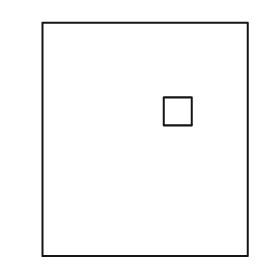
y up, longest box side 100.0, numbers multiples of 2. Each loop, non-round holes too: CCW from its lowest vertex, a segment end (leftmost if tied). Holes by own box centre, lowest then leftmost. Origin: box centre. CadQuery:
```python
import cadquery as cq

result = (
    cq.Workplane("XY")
    .moveTo(-44.0, -50.0)
    .lineTo(44.0, -50.0)
    .lineTo(44.0, 50.0)
    .lineTo(-44.0, 50.0)
    .close()
    .moveTo(8.0, 6.0)
    .lineTo(20.0, 6.0)
    .lineTo(20.0, 18.0)
    .lineTo(8.0, 18.0)
    .close()
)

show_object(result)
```